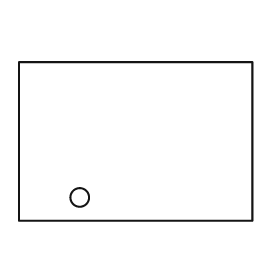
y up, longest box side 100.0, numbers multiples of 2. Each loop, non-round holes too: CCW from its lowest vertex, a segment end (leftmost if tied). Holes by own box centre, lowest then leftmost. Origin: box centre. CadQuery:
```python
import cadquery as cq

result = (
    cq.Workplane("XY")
    .moveTo(-50.0, -34.0)
    .lineTo(50.0, -34.0)
    .lineTo(50.0, 34.0)
    .lineTo(-50.0, 34.0)
    .close()
    .moveTo(-24.0, -24.0)
    .circle(4.0)
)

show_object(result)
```